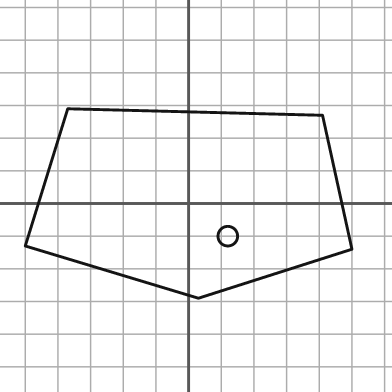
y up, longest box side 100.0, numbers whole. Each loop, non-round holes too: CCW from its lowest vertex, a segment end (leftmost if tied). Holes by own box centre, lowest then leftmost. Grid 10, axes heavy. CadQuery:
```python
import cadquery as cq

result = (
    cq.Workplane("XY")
    .moveTo(3.0, -29.0)
    .lineTo(50.0, -14.0)
    .lineTo(41.0, 27.0)
    .lineTo(-37.0, 29.0)
    .lineTo(-50.0, -13.0)
    .close()
    .moveTo(12.0, -10.0)
    .circle(3.0)
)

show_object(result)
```